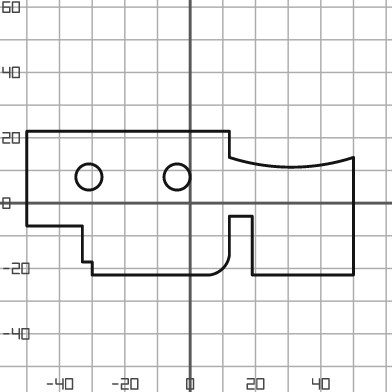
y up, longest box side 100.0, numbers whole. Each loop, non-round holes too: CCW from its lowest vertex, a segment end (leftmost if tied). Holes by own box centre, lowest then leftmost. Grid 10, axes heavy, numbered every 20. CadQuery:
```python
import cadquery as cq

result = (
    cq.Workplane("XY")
    .moveTo(-30.0, -22.0)
    .lineTo(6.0, -22.0)
    .threePointArc((10.0, -20.0), (12.0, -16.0))
    .lineTo(12.0, -4.0)
    .lineTo(19.0, -4.0)
    .lineTo(19.0, -22.0)
    .lineTo(50.0, -22.0)
    .lineTo(50.0, 14.0)
    .threePointArc((31.0, 11.0), (12.0, 14.0))
    .lineTo(12.0, 22.0)
    .lineTo(-50.0, 22.0)
    .lineTo(-50.0, -7.0)
    .lineTo(-33.0, -7.0)
    .lineTo(-33.0, -18.0)
    .lineTo(-30.0, -18.0)
    .close()
    .moveTo(-31.0, 8.0)
    .circle(4.0)
    .moveTo(-4.0, 8.0)
    .circle(4.0)
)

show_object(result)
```